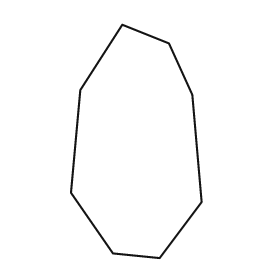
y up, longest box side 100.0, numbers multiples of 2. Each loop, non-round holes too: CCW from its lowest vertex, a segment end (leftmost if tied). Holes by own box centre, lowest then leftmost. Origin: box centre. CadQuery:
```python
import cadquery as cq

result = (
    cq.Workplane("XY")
    .moveTo(10.0, -50.0)
    .lineTo(28.0, -26.0)
    .lineTo(24.0, 20.0)
    .lineTo(14.0, 42.0)
    .lineTo(-6.0, 50.0)
    .lineTo(-24.0, 22.0)
    .lineTo(-28.0, -22.0)
    .lineTo(-10.0, -48.0)
    .close()
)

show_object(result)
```